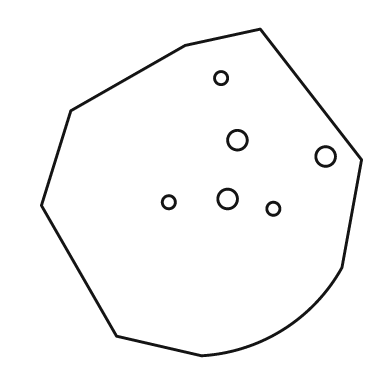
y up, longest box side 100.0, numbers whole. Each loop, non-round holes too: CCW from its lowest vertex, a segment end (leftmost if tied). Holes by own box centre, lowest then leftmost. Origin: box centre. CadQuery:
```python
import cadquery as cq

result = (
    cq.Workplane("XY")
    .moveTo(0.0, -50.0)
    .threePointArc((25.0, -42.0), (43.0, -23.0))
    .lineTo(49.0, 10.0)
    .lineTo(18.0, 50.0)
    .lineTo(-5.0, 45.0)
    .lineTo(-40.0, 25.0)
    .lineTo(-49.0, -4.0)
    .lineTo(-26.0, -44.0)
    .close()
    .moveTo(22.0, -5.0)
    .circle(2.0)
    .moveTo(-10.0, -3.0)
    .circle(2.0)
    .moveTo(8.0, -2.0)
    .circle(3.0)
    .moveTo(38.0, 11.0)
    .circle(3.0)
    .moveTo(11.0, 16.0)
    .circle(3.0)
    .moveTo(6.0, 35.0)
    .circle(2.0)
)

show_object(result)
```